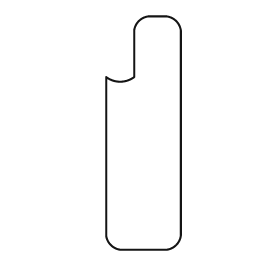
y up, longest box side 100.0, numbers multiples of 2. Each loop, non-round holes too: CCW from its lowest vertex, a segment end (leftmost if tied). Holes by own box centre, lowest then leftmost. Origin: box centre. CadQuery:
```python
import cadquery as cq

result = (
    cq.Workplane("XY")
    .moveTo(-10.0, -50.0)
    .lineTo(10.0, -50.0)
    .threePointArc((14.0, -48.0), (16.0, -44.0))
    .lineTo(16.0, 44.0)
    .threePointArc((14.0, 48.0), (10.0, 50.0))
    .lineTo(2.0, 50.0)
    .threePointArc((-2.0, 48.0), (-4.0, 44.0))
    .lineTo(-4.0, 24.0)
    .threePointArc((-10.0, 22.0), (-16.0, 24.0))
    .lineTo(-16.0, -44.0)
    .threePointArc((-14.0, -48.0), (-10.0, -50.0))
    .close()
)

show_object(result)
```